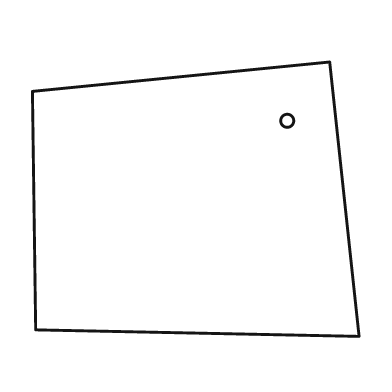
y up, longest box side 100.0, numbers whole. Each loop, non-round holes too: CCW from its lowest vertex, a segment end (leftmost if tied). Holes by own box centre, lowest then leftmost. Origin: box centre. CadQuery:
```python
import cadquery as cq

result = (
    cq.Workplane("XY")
    .moveTo(50.0, -42.0)
    .lineTo(41.0, 42.0)
    .lineTo(-50.0, 33.0)
    .lineTo(-49.0, -40.0)
    .close()
    .moveTo(28.0, 24.0)
    .circle(2.0)
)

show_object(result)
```